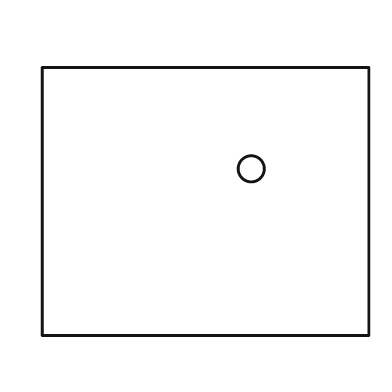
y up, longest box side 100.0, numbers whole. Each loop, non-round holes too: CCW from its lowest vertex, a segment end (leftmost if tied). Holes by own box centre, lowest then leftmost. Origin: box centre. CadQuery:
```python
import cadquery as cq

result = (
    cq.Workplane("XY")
    .moveTo(-50.0, -41.0)
    .lineTo(50.0, -41.0)
    .lineTo(50.0, 41.0)
    .lineTo(-50.0, 41.0)
    .close()
    .moveTo(14.0, 10.0)
    .circle(4.0)
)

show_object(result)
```